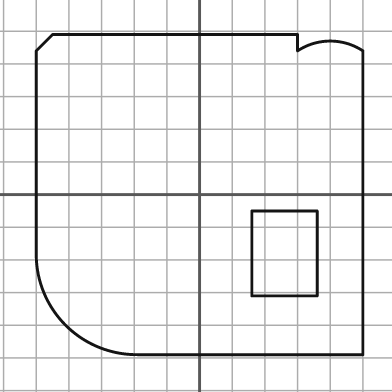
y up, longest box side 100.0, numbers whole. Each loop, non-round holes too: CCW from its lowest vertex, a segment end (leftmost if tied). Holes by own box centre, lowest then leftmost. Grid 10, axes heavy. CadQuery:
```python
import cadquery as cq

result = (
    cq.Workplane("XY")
    .moveTo(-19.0, -49.0)
    .lineTo(50.0, -49.0)
    .lineTo(50.0, 44.0)
    .threePointArc((40.0, 47.0), (30.0, 44.0))
    .lineTo(30.0, 49.0)
    .lineTo(-45.0, 49.0)
    .lineTo(-50.0, 44.0)
    .lineTo(-50.0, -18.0)
    .threePointArc((-41.0, -40.0), (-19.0, -49.0))
    .close()
    .moveTo(16.0, -31.0)
    .lineTo(36.0, -31.0)
    .lineTo(36.0, -5.0)
    .lineTo(16.0, -5.0)
    .close()
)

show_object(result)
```